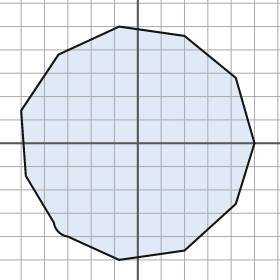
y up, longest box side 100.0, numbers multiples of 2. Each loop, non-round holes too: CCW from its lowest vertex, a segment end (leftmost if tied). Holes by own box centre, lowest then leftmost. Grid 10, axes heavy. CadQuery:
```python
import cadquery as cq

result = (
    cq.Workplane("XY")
    .moveTo(-8.0, -50.0)
    .lineTo(20.0, -46.0)
    .lineTo(42.0, -26.0)
    .lineTo(50.0, 0.0)
    .lineTo(42.0, 28.0)
    .lineTo(20.0, 46.0)
    .lineTo(-8.0, 50.0)
    .lineTo(-34.0, 38.0)
    .lineTo(-50.0, 14.0)
    .lineTo(-48.0, -14.0)
    .lineTo(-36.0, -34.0)
    .threePointArc((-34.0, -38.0), (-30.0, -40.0))
    .close()
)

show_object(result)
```